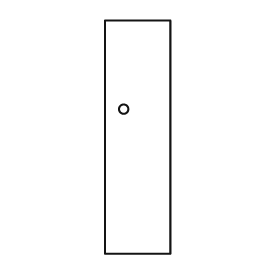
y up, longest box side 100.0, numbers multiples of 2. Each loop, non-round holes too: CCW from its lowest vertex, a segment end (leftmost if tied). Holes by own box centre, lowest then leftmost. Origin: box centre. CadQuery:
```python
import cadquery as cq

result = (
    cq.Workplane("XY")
    .moveTo(-14.0, -50.0)
    .lineTo(14.0, -50.0)
    .lineTo(14.0, 50.0)
    .lineTo(-14.0, 50.0)
    .close()
    .moveTo(-6.0, 12.0)
    .circle(2.0)
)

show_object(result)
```